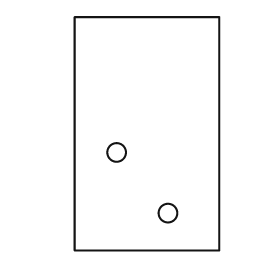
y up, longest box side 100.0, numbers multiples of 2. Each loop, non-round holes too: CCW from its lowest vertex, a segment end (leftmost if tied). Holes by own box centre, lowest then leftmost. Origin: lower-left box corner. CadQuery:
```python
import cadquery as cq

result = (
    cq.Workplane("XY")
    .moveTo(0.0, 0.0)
    .lineTo(62.0, 0.0)
    .lineTo(62.0, 100.0)
    .lineTo(0.0, 100.0)
    .close()
    .moveTo(40.0, 16.0)
    .circle(4.0)
    .moveTo(18.0, 42.0)
    .circle(4.0)
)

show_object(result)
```